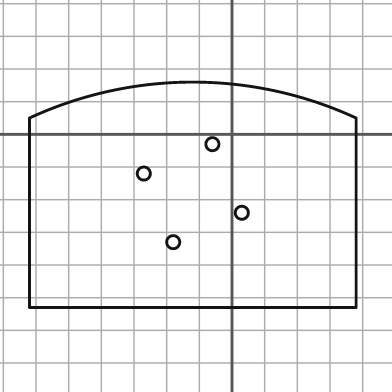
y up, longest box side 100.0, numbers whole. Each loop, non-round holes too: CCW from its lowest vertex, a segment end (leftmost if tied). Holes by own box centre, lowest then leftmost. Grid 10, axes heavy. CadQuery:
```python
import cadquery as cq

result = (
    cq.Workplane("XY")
    .moveTo(-62.0, -53.0)
    .lineTo(38.0, -53.0)
    .lineTo(38.0, 5.0)
    .threePointArc((-12.0, 16.0), (-62.0, 5.0))
    .close()
    .moveTo(-18.0, -33.0)
    .circle(2.0)
    .moveTo(3.0, -24.0)
    .circle(2.0)
    .moveTo(-27.0, -12.0)
    .circle(2.0)
    .moveTo(-6.0, -3.0)
    .circle(2.0)
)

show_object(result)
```